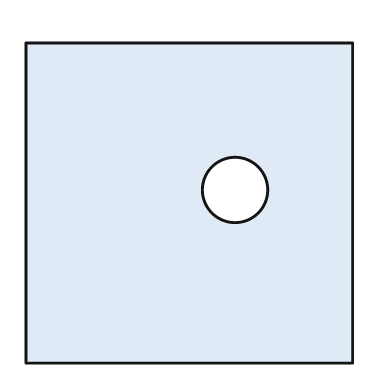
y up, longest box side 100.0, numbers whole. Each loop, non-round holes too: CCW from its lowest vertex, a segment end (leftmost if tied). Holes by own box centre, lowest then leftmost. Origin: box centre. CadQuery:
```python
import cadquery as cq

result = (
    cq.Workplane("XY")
    .moveTo(-50.0, -49.0)
    .lineTo(50.0, -49.0)
    .lineTo(50.0, 49.0)
    .lineTo(-50.0, 49.0)
    .close()
    .moveTo(14.0, 4.0)
    .circle(10.0)
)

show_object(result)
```